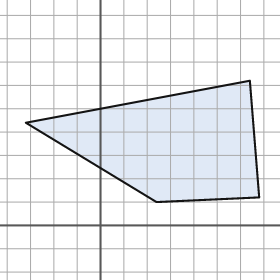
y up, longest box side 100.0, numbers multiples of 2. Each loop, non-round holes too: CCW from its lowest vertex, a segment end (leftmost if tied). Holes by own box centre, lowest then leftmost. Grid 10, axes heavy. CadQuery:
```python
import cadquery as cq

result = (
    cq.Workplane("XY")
    .moveTo(24.0, 10.0)
    .lineTo(68.0, 12.0)
    .lineTo(64.0, 62.0)
    .lineTo(-32.0, 44.0)
    .close()
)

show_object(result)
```